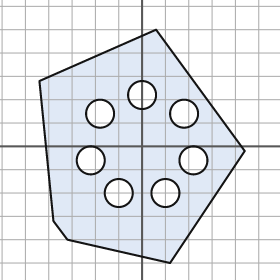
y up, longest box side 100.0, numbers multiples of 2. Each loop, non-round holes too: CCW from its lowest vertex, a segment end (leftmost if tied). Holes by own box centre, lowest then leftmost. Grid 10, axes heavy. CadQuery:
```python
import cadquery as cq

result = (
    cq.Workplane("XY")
    .moveTo(12.0, -50.0)
    .lineTo(44.0, -2.0)
    .lineTo(6.0, 50.0)
    .lineTo(-44.0, 28.0)
    .lineTo(-38.0, -32.0)
    .lineTo(-32.0, -40.0)
    .close()
    .moveTo(-10.0, -20.0)
    .circle(6.0)
    .moveTo(10.0, -20.0)
    .circle(6.0)
    .moveTo(-22.0, -6.0)
    .circle(6.0)
    .moveTo(22.0, -6.0)
    .circle(6.0)
    .moveTo(-18.0, 14.0)
    .circle(6.0)
    .moveTo(18.0, 14.0)
    .circle(6.0)
    .moveTo(0.0, 22.0)
    .circle(6.0)
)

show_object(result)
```